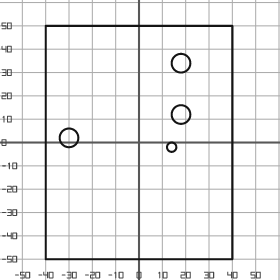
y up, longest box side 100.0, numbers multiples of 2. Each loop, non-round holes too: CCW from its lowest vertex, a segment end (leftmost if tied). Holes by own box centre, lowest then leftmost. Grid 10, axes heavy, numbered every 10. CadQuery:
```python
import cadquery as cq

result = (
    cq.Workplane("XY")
    .moveTo(-40.0, -50.0)
    .lineTo(40.0, -50.0)
    .lineTo(40.0, 50.0)
    .lineTo(-40.0, 50.0)
    .close()
    .moveTo(14.0, -2.0)
    .circle(2.0)
    .moveTo(-30.0, 2.0)
    .circle(4.0)
    .moveTo(18.0, 12.0)
    .circle(4.0)
    .moveTo(18.0, 34.0)
    .circle(4.0)
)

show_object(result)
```